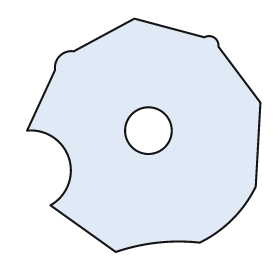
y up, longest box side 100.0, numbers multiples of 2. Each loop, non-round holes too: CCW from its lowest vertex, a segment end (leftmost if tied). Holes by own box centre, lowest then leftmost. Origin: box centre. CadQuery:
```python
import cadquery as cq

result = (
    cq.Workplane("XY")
    .moveTo(-12.0, -50.0)
    .threePointArc((6.0, -46.0), (24.0, -46.0))
    .threePointArc((38.0, -36.0), (48.0, -22.0))
    .lineTo(50.0, 14.0)
    .lineTo(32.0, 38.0)
    .threePointArc((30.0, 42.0), (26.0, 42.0))
    .lineTo(-4.0, 50.0)
    .lineTo(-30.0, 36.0)
    .threePointArc((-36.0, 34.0), (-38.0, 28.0))
    .lineTo(-50.0, 2.0)
    .threePointArc((-32.0, -10.0), (-40.0, -30.0))
    .close()
    .moveTo(2.0, 2.0)
    .circle(10.0)
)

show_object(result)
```